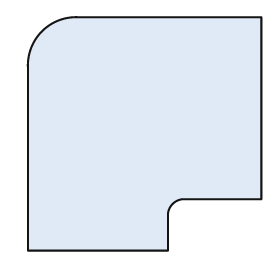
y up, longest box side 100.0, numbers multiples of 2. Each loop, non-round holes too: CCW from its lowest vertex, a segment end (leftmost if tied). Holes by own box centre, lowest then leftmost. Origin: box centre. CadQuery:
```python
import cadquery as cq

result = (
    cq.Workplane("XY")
    .moveTo(-50.0, -50.0)
    .lineTo(10.0, -50.0)
    .lineTo(10.0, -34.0)
    .threePointArc((12.0, -30.0), (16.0, -28.0))
    .lineTo(50.0, -28.0)
    .lineTo(50.0, 50.0)
    .lineTo(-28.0, 50.0)
    .threePointArc((-44.0, 44.0), (-50.0, 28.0))
    .close()
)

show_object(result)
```